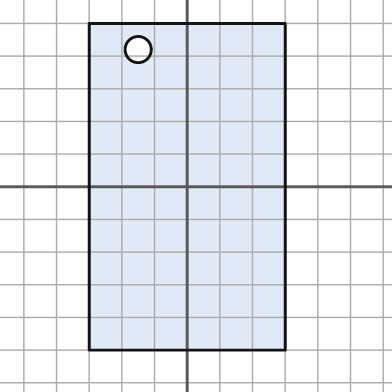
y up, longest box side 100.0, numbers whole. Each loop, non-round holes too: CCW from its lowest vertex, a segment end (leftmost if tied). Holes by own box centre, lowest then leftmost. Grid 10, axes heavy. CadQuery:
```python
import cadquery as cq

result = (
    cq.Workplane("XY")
    .moveTo(-30.0, -50.0)
    .lineTo(30.0, -50.0)
    .lineTo(30.0, 50.0)
    .lineTo(-30.0, 50.0)
    .close()
    .moveTo(-15.0, 42.0)
    .circle(4.0)
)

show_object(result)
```